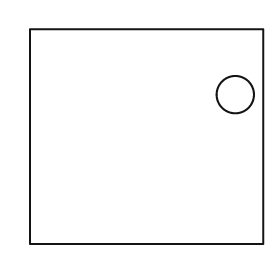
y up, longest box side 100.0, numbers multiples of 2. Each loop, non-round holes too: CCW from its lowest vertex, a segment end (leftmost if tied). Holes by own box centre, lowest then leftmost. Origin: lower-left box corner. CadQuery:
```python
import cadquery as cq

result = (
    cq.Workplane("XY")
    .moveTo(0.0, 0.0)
    .lineTo(100.0, 0.0)
    .lineTo(100.0, 92.0)
    .lineTo(0.0, 92.0)
    .close()
    .moveTo(88.0, 64.0)
    .circle(8.0)
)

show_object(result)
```